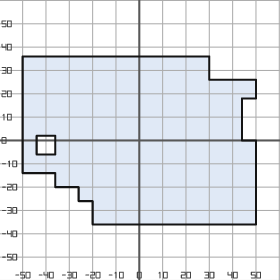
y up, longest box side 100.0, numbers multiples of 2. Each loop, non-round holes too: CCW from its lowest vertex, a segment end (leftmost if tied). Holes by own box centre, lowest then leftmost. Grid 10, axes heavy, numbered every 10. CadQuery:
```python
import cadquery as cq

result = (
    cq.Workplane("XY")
    .moveTo(-20.0, -36.0)
    .lineTo(50.0, -36.0)
    .lineTo(50.0, 0.0)
    .lineTo(44.0, 0.0)
    .lineTo(44.0, 18.0)
    .lineTo(50.0, 18.0)
    .lineTo(50.0, 26.0)
    .lineTo(30.0, 26.0)
    .lineTo(30.0, 36.0)
    .lineTo(-50.0, 36.0)
    .lineTo(-50.0, -14.0)
    .lineTo(-36.0, -14.0)
    .lineTo(-36.0, -20.0)
    .lineTo(-26.0, -20.0)
    .lineTo(-26.0, -26.0)
    .lineTo(-20.0, -26.0)
    .close()
    .moveTo(-44.0, -6.0)
    .lineTo(-36.0, -6.0)
    .lineTo(-36.0, 2.0)
    .lineTo(-44.0, 2.0)
    .close()
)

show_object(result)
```